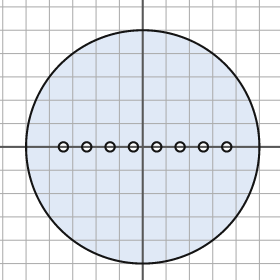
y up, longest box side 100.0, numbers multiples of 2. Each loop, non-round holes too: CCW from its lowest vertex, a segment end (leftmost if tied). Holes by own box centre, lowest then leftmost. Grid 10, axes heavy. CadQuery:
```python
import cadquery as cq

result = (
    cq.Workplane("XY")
    .moveTo(0.0, 0.0)
    .circle(50.0)
    .moveTo(-34.0, 0.0)
    .circle(2.0)
    .moveTo(-24.0, 0.0)
    .circle(2.0)
    .moveTo(-14.0, 0.0)
    .circle(2.0)
    .moveTo(-4.0, 0.0)
    .circle(2.0)
    .moveTo(6.0, 0.0)
    .circle(2.0)
    .moveTo(16.0, 0.0)
    .circle(2.0)
    .moveTo(26.0, 0.0)
    .circle(2.0)
    .moveTo(36.0, 0.0)
    .circle(2.0)
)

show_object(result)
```